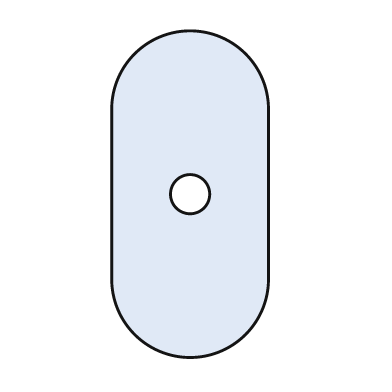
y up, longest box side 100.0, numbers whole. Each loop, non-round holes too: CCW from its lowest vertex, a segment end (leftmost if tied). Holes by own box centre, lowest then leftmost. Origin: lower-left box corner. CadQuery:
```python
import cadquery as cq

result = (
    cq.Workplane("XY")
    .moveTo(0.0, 24.0)
    .threePointArc((24.0, 0.0), (48.0, 24.0))
    .lineTo(48.0, 76.0)
    .threePointArc((24.0, 100.0), (0.0, 76.0))
    .close()
    .moveTo(24.0, 50.0)
    .circle(6.0)
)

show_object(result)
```